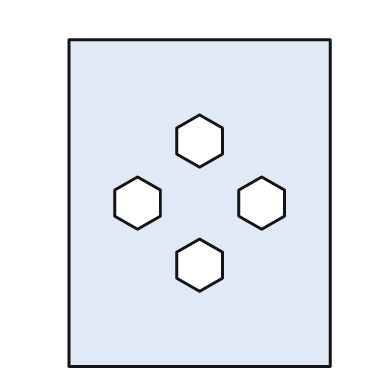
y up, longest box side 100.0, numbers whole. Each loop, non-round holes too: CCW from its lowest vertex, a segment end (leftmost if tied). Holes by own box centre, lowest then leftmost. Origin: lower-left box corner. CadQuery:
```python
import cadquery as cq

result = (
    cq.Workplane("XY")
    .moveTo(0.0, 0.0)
    .lineTo(80.0, 0.0)
    .lineTo(80.0, 100.0)
    .lineTo(0.0, 100.0)
    .close()
    .moveTo(40.0, 23.0)
    .lineTo(47.0, 27.0)
    .lineTo(47.0, 35.0)
    .lineTo(40.0, 39.0)
    .lineTo(33.0, 35.0)
    .lineTo(33.0, 27.0)
    .close()
    .moveTo(21.0, 42.0)
    .lineTo(28.0, 46.0)
    .lineTo(28.0, 54.0)
    .lineTo(21.0, 58.0)
    .lineTo(14.0, 54.0)
    .lineTo(14.0, 46.0)
    .close()
    .moveTo(59.0, 42.0)
    .lineTo(66.0, 46.0)
    .lineTo(66.0, 54.0)
    .lineTo(59.0, 58.0)
    .lineTo(52.0, 54.0)
    .lineTo(52.0, 46.0)
    .close()
    .moveTo(40.0, 61.0)
    .lineTo(47.0, 65.0)
    .lineTo(47.0, 73.0)
    .lineTo(40.0, 77.0)
    .lineTo(33.0, 73.0)
    .lineTo(33.0, 65.0)
    .close()
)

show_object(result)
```